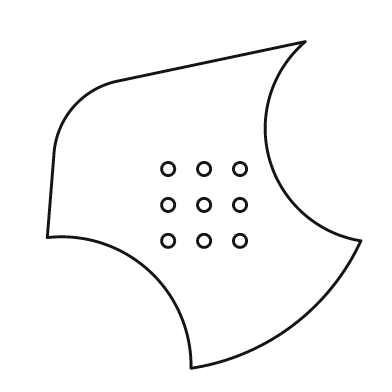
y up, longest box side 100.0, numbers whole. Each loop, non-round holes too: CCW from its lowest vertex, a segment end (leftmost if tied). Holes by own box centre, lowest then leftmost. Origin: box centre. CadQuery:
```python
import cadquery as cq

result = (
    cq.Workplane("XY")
    .moveTo(-4.0, -50.0)
    .threePointArc((27.0, -37.0), (48.0, -11.0))
    .threePointArc((20.0, 14.0), (31.0, 50.0))
    .lineTo(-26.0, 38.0)
    .threePointArc((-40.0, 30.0), (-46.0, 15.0))
    .lineTo(-48.0, -10.0)
    .threePointArc((-17.0, -20.0), (-4.0, -50.0))
    .close()
    .moveTo(-11.0, -11.0)
    .circle(2.0)
    .moveTo(0.0, -11.0)
    .circle(2.0)
    .moveTo(11.0, -11.0)
    .circle(2.0)
    .moveTo(-11.0, 0.0)
    .circle(2.0)
    .moveTo(0.0, 0.0)
    .circle(2.0)
    .moveTo(11.0, 0.0)
    .circle(2.0)
    .moveTo(-11.0, 11.0)
    .circle(2.0)
    .moveTo(0.0, 11.0)
    .circle(2.0)
    .moveTo(11.0, 11.0)
    .circle(2.0)
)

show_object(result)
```